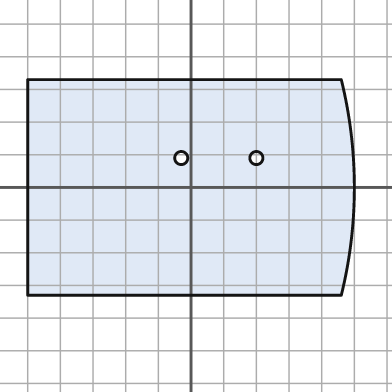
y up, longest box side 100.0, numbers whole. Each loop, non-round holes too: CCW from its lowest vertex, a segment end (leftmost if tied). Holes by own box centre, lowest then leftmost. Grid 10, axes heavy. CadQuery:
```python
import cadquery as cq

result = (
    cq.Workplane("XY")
    .moveTo(-50.0, -33.0)
    .lineTo(46.0, -33.0)
    .threePointArc((50.0, 0.0), (46.0, 33.0))
    .lineTo(-50.0, 33.0)
    .close()
    .moveTo(-3.0, 9.0)
    .circle(2.0)
    .moveTo(20.0, 9.0)
    .circle(2.0)
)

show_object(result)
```